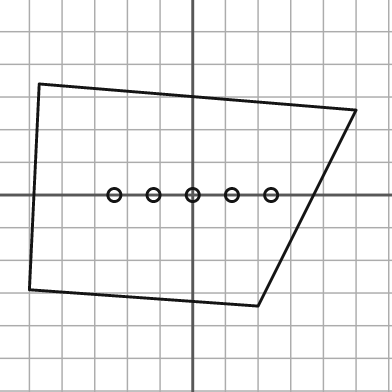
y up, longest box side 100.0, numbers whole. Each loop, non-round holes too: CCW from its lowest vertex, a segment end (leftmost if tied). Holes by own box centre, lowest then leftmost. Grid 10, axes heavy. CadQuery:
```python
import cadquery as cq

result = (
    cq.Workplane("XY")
    .moveTo(20.0, -34.0)
    .lineTo(50.0, 26.0)
    .lineTo(-47.0, 34.0)
    .lineTo(-50.0, -29.0)
    .close()
    .moveTo(-24.0, 0.0)
    .circle(2.0)
    .moveTo(-12.0, 0.0)
    .circle(2.0)
    .moveTo(0.0, 0.0)
    .circle(2.0)
    .moveTo(12.0, 0.0)
    .circle(2.0)
    .moveTo(24.0, 0.0)
    .circle(2.0)
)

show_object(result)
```